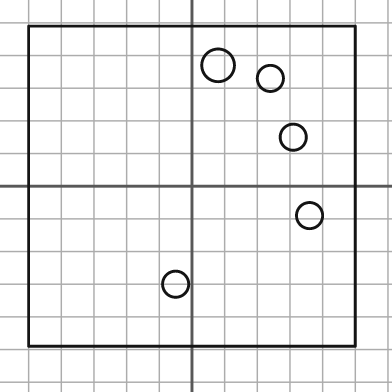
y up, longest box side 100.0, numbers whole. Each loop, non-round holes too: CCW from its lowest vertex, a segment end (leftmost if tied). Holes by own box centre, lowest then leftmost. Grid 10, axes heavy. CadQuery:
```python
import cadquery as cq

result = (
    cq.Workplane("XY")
    .moveTo(-50.0, -49.0)
    .lineTo(50.0, -49.0)
    .lineTo(50.0, 49.0)
    .lineTo(-50.0, 49.0)
    .close()
    .moveTo(-5.0, -30.0)
    .circle(4.0)
    .moveTo(36.0, -9.0)
    .circle(4.0)
    .moveTo(31.0, 15.0)
    .circle(4.0)
    .moveTo(24.0, 33.0)
    .circle(4.0)
    .moveTo(8.0, 37.0)
    .circle(5.0)
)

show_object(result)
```